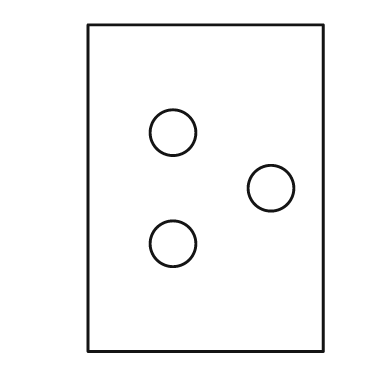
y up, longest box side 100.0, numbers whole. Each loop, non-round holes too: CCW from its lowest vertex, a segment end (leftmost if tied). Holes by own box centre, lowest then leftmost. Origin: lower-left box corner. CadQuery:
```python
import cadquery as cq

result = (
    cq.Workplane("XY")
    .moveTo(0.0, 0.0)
    .lineTo(72.0, 0.0)
    .lineTo(72.0, 100.0)
    .lineTo(0.0, 100.0)
    .close()
    .moveTo(26.0, 33.0)
    .circle(7.0)
    .moveTo(56.0, 50.0)
    .circle(7.0)
    .moveTo(26.0, 67.0)
    .circle(7.0)
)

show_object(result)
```